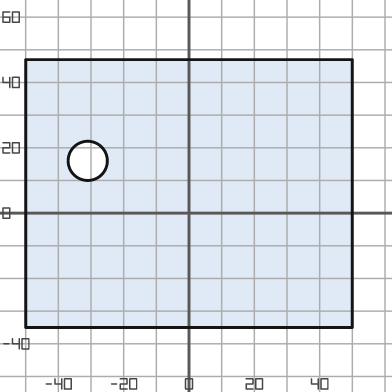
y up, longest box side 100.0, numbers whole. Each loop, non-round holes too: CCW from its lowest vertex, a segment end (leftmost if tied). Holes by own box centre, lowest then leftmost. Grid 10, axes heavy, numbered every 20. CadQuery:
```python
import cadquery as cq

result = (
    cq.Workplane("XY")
    .moveTo(-50.0, -35.0)
    .lineTo(50.0, -35.0)
    .lineTo(50.0, 47.0)
    .lineTo(-50.0, 47.0)
    .close()
    .moveTo(-31.0, 16.0)
    .circle(6.0)
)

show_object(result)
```